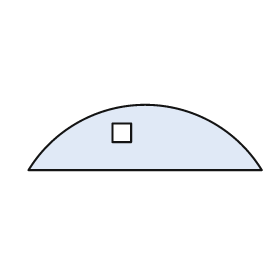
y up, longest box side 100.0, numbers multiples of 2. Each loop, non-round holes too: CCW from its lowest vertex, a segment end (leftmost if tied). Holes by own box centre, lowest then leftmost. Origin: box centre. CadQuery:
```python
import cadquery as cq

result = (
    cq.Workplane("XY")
    .moveTo(-50.0, -14.0)
    .lineTo(50.0, -14.0)
    .threePointArc((0.0, 14.0), (-50.0, -14.0))
    .close()
    .moveTo(-14.0, -2.0)
    .lineTo(-6.0, -2.0)
    .lineTo(-6.0, 6.0)
    .lineTo(-14.0, 6.0)
    .close()
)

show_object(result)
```